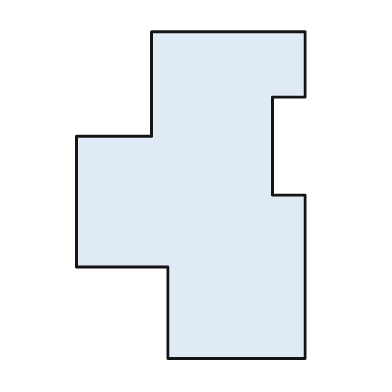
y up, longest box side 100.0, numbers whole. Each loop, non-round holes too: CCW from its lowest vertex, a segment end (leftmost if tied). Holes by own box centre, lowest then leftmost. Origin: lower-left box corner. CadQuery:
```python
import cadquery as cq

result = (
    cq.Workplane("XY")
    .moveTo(28.0, 0.0)
    .lineTo(70.0, 0.0)
    .lineTo(70.0, 50.0)
    .lineTo(60.0, 50.0)
    .lineTo(60.0, 80.0)
    .lineTo(70.0, 80.0)
    .lineTo(70.0, 100.0)
    .lineTo(23.0, 100.0)
    .lineTo(23.0, 68.0)
    .lineTo(0.0, 68.0)
    .lineTo(0.0, 28.0)
    .lineTo(28.0, 28.0)
    .close()
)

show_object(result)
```